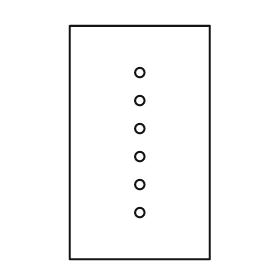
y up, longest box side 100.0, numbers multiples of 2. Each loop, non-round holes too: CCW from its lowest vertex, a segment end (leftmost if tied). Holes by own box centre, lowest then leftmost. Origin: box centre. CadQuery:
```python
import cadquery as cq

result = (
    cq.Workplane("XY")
    .moveTo(-30.0, -50.0)
    .lineTo(30.0, -50.0)
    .lineTo(30.0, 50.0)
    .lineTo(-30.0, 50.0)
    .close()
    .moveTo(0.0, -30.0)
    .circle(2.0)
    .moveTo(0.0, -18.0)
    .circle(2.0)
    .moveTo(0.0, -6.0)
    .circle(2.0)
    .moveTo(0.0, 6.0)
    .circle(2.0)
    .moveTo(0.0, 18.0)
    .circle(2.0)
    .moveTo(0.0, 30.0)
    .circle(2.0)
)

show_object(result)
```